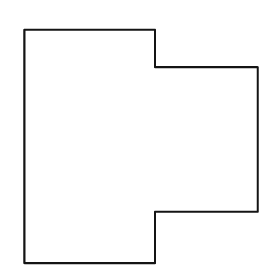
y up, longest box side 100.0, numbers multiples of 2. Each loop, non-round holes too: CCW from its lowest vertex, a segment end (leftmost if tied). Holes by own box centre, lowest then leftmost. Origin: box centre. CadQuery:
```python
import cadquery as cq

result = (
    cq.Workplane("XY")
    .moveTo(-50.0, -50.0)
    .lineTo(6.0, -50.0)
    .lineTo(6.0, -28.0)
    .lineTo(50.0, -28.0)
    .lineTo(50.0, 34.0)
    .lineTo(6.0, 34.0)
    .lineTo(6.0, 50.0)
    .lineTo(-50.0, 50.0)
    .close()
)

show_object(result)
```